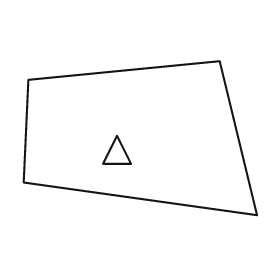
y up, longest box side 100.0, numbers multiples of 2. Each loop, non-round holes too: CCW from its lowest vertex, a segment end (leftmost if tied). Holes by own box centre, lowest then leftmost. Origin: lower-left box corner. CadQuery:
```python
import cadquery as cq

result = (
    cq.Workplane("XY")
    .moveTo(100.0, 0.0)
    .lineTo(84.0, 66.0)
    .lineTo(2.0, 58.0)
    .lineTo(0.0, 14.0)
    .close()
    .moveTo(34.0, 22.0)
    .lineTo(46.0, 22.0)
    .lineTo(40.0, 34.0)
    .close()
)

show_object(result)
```